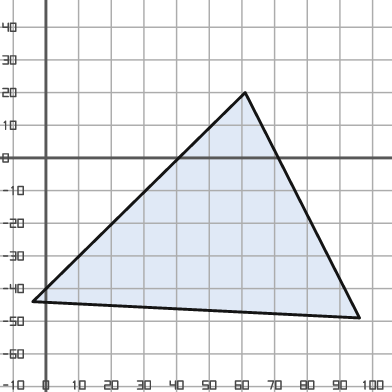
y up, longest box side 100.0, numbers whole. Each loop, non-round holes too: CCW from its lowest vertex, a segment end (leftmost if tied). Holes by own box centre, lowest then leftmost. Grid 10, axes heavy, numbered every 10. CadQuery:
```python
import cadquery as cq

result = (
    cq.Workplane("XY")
    .moveTo(96.0, -49.0)
    .lineTo(61.0, 20.0)
    .lineTo(-4.0, -44.0)
    .close()
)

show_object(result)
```